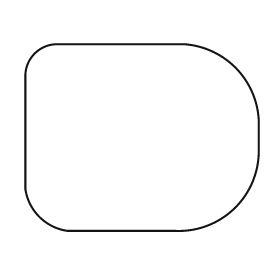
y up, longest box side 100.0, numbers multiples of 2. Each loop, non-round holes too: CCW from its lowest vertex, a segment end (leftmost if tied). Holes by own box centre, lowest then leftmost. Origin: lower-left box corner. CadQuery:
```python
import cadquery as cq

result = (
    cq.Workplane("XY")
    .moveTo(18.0, 0.0)
    .lineTo(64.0, 0.0)
    .threePointArc((90.0, 10.0), (100.0, 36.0))
    .lineTo(100.0, 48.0)
    .threePointArc((90.0, 70.0), (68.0, 80.0))
    .lineTo(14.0, 80.0)
    .threePointArc((4.0, 76.0), (0.0, 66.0))
    .lineTo(0.0, 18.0)
    .threePointArc((6.0, 6.0), (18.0, 0.0))
    .close()
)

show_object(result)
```